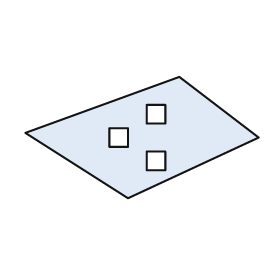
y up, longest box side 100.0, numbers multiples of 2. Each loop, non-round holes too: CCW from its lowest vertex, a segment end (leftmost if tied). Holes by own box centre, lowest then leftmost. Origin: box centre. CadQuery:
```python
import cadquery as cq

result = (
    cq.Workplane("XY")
    .moveTo(-6.0, -26.0)
    .lineTo(50.0, 0.0)
    .lineTo(16.0, 26.0)
    .lineTo(-50.0, 2.0)
    .close()
    .moveTo(2.0, -14.0)
    .lineTo(10.0, -14.0)
    .lineTo(10.0, -6.0)
    .lineTo(2.0, -6.0)
    .close()
    .moveTo(-14.0, -4.0)
    .lineTo(-6.0, -4.0)
    .lineTo(-6.0, 4.0)
    .lineTo(-14.0, 4.0)
    .close()
    .moveTo(2.0, 6.0)
    .lineTo(10.0, 6.0)
    .lineTo(10.0, 14.0)
    .lineTo(2.0, 14.0)
    .close()
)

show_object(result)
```